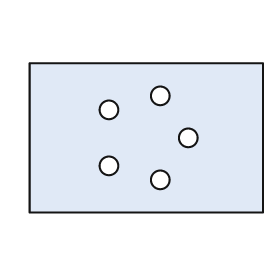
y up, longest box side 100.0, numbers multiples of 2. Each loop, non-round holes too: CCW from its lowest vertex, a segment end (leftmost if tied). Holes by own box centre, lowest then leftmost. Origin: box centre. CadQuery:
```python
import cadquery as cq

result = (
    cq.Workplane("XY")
    .moveTo(-50.0, -32.0)
    .lineTo(50.0, -32.0)
    .lineTo(50.0, 32.0)
    .lineTo(-50.0, 32.0)
    .close()
    .moveTo(6.0, -18.0)
    .circle(4.0)
    .moveTo(-16.0, -12.0)
    .circle(4.0)
    .moveTo(18.0, 0.0)
    .circle(4.0)
    .moveTo(-16.0, 12.0)
    .circle(4.0)
    .moveTo(6.0, 18.0)
    .circle(4.0)
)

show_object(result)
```